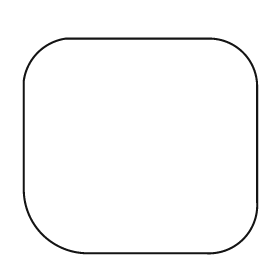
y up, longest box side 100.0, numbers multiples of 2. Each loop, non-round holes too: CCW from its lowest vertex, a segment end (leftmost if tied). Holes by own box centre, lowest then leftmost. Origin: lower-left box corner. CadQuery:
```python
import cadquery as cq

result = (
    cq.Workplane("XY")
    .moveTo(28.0, 0.0)
    .lineTo(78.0, 0.0)
    .threePointArc((94.0, 6.0), (100.0, 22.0))
    .lineTo(100.0, 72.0)
    .threePointArc((94.0, 86.0), (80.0, 92.0))
    .lineTo(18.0, 92.0)
    .threePointArc((6.0, 86.0), (0.0, 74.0))
    .lineTo(0.0, 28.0)
    .threePointArc((8.0, 8.0), (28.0, 0.0))
    .close()
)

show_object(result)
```